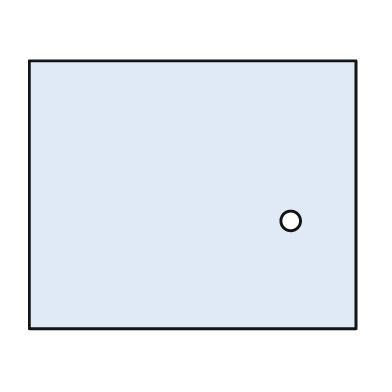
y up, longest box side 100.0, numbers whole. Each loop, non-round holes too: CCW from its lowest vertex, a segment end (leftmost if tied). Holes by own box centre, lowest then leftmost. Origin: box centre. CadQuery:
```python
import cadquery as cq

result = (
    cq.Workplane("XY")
    .moveTo(-50.0, -41.0)
    .lineTo(50.0, -41.0)
    .lineTo(50.0, 41.0)
    .lineTo(-50.0, 41.0)
    .close()
    .moveTo(30.0, -8.0)
    .circle(3.0)
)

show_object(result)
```